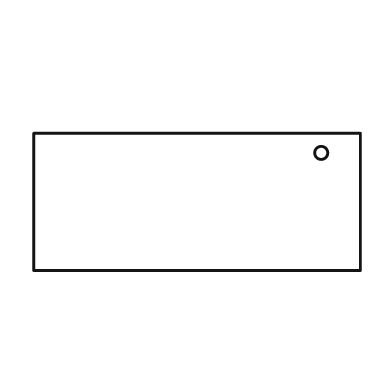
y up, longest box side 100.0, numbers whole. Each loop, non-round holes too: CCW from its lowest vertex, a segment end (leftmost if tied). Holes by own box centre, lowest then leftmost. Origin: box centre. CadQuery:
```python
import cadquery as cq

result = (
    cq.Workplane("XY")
    .moveTo(-50.0, -21.0)
    .lineTo(50.0, -21.0)
    .lineTo(50.0, 21.0)
    .lineTo(-50.0, 21.0)
    .close()
    .moveTo(38.0, 15.0)
    .circle(2.0)
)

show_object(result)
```